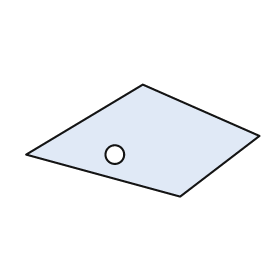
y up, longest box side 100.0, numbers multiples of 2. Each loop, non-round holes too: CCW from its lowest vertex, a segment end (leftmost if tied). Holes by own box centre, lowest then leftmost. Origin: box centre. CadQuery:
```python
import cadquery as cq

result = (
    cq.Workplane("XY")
    .moveTo(16.0, -24.0)
    .lineTo(50.0, 2.0)
    .lineTo(0.0, 24.0)
    .lineTo(-50.0, -6.0)
    .close()
    .moveTo(-12.0, -6.0)
    .circle(4.0)
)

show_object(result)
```